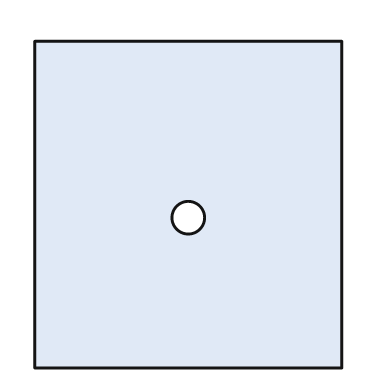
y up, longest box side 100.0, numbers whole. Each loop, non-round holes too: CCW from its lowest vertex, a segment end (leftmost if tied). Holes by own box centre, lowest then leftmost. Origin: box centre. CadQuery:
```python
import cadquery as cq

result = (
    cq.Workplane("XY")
    .moveTo(-47.0, -50.0)
    .lineTo(47.0, -50.0)
    .lineTo(47.0, 50.0)
    .lineTo(-47.0, 50.0)
    .close()
    .moveTo(0.0, -4.0)
    .circle(5.0)
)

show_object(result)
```